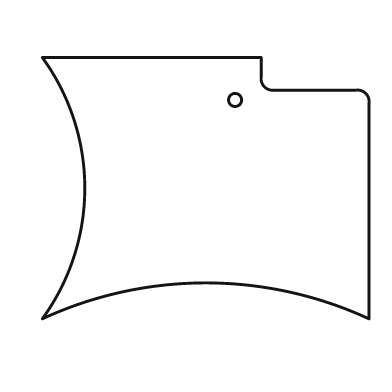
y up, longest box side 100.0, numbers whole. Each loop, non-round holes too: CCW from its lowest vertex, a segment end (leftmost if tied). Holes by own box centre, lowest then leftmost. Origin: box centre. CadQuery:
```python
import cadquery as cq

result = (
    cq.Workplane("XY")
    .moveTo(-50.0, -40.0)
    .threePointArc((0.0, -29.0), (50.0, -40.0))
    .lineTo(50.0, 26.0)
    .threePointArc((49.0, 29.0), (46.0, 30.0))
    .lineTo(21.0, 30.0)
    .threePointArc((18.0, 31.0), (17.0, 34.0))
    .lineTo(17.0, 40.0)
    .lineTo(-50.0, 40.0)
    .threePointArc((-37.0, 0.0), (-50.0, -40.0))
    .close()
    .moveTo(9.0, 27.0)
    .circle(2.0)
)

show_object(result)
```